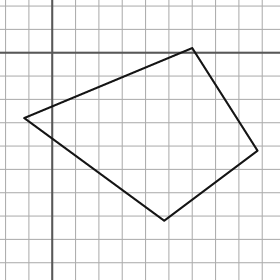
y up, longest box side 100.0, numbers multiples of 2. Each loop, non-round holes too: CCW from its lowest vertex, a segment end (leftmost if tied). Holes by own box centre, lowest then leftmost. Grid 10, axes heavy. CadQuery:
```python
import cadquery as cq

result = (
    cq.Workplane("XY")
    .moveTo(48.0, -72.0)
    .lineTo(88.0, -42.0)
    .lineTo(60.0, 2.0)
    .lineTo(-12.0, -28.0)
    .close()
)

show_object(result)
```